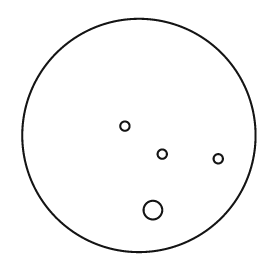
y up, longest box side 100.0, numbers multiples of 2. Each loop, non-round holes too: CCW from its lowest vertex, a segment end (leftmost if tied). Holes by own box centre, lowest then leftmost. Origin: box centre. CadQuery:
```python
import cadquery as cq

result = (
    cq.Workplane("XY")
    .moveTo(0.0, 0.0)
    .circle(50.0)
    .moveTo(6.0, -32.0)
    .circle(4.0)
    .moveTo(34.0, -10.0)
    .circle(2.0)
    .moveTo(10.0, -8.0)
    .circle(2.0)
    .moveTo(-6.0, 4.0)
    .circle(2.0)
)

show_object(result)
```